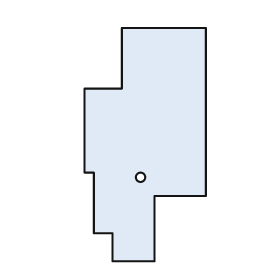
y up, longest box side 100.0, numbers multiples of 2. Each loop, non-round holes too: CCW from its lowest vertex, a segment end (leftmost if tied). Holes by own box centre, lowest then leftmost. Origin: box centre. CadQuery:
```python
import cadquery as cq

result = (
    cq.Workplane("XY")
    .moveTo(-14.0, -50.0)
    .lineTo(4.0, -50.0)
    .lineTo(4.0, -22.0)
    .lineTo(26.0, -22.0)
    .lineTo(26.0, 50.0)
    .lineTo(-10.0, 50.0)
    .lineTo(-10.0, 24.0)
    .lineTo(-26.0, 24.0)
    .lineTo(-26.0, -12.0)
    .lineTo(-22.0, -12.0)
    .lineTo(-22.0, -38.0)
    .lineTo(-14.0, -38.0)
    .close()
    .moveTo(-2.0, -14.0)
    .circle(2.0)
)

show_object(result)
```